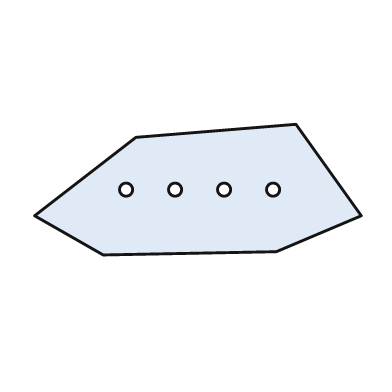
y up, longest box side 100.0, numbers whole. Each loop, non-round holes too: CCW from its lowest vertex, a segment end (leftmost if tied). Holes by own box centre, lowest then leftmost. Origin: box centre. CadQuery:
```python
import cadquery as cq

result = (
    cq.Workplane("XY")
    .moveTo(-29.0, -20.0)
    .lineTo(24.0, -19.0)
    .lineTo(50.0, -8.0)
    .lineTo(30.0, 20.0)
    .lineTo(-19.0, 16.0)
    .lineTo(-50.0, -8.0)
    .close()
    .moveTo(-22.0, 0.0)
    .circle(2.0)
    .moveTo(-7.0, 0.0)
    .circle(2.0)
    .moveTo(8.0, 0.0)
    .circle(2.0)
    .moveTo(23.0, 0.0)
    .circle(2.0)
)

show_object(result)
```